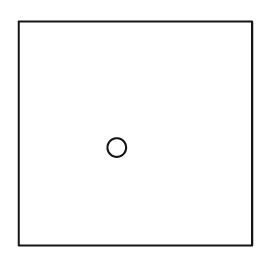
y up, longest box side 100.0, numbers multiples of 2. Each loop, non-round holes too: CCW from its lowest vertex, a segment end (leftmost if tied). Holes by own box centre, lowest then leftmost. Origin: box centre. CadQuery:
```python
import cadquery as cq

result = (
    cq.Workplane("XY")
    .moveTo(-50.0, -48.0)
    .lineTo(50.0, -48.0)
    .lineTo(50.0, 48.0)
    .lineTo(-50.0, 48.0)
    .close()
    .moveTo(-8.0, -6.0)
    .circle(4.0)
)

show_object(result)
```